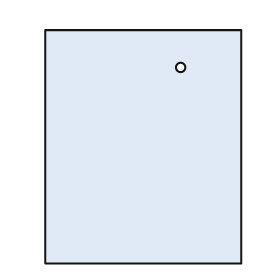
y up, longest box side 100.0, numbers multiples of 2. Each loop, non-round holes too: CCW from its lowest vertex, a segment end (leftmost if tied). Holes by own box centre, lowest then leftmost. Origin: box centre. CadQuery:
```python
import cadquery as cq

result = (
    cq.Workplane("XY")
    .moveTo(-42.0, -50.0)
    .lineTo(42.0, -50.0)
    .lineTo(42.0, 50.0)
    .lineTo(-42.0, 50.0)
    .close()
    .moveTo(16.0, 34.0)
    .circle(2.0)
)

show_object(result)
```